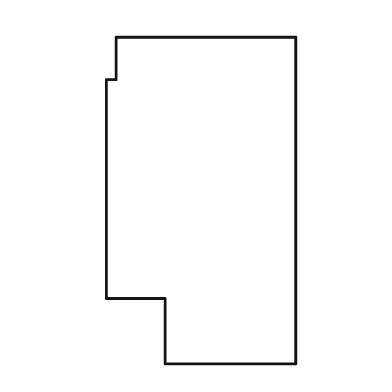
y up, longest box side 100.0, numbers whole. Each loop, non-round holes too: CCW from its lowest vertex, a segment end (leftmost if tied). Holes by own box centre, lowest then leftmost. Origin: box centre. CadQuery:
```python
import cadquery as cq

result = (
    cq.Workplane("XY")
    .moveTo(-11.0, -50.0)
    .lineTo(29.0, -50.0)
    .lineTo(29.0, 50.0)
    .lineTo(-26.0, 50.0)
    .lineTo(-26.0, 37.0)
    .lineTo(-29.0, 37.0)
    .lineTo(-29.0, -30.0)
    .lineTo(-11.0, -30.0)
    .close()
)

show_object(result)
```